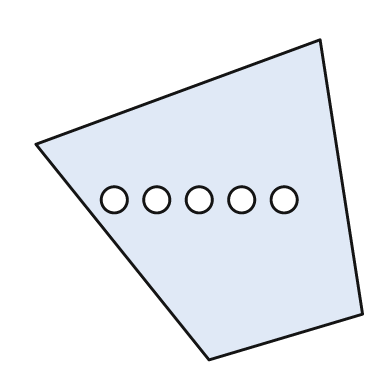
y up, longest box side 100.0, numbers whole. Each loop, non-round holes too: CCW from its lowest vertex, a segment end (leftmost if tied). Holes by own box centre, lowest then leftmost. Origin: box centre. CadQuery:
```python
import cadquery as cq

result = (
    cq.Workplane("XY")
    .moveTo(3.0, -49.0)
    .lineTo(50.0, -35.0)
    .lineTo(37.0, 49.0)
    .lineTo(-50.0, 17.0)
    .close()
    .moveTo(-26.0, 0.0)
    .circle(4.0)
    .moveTo(-13.0, 0.0)
    .circle(4.0)
    .moveTo(0.0, 0.0)
    .circle(4.0)
    .moveTo(13.0, 0.0)
    .circle(4.0)
    .moveTo(26.0, 0.0)
    .circle(4.0)
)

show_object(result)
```